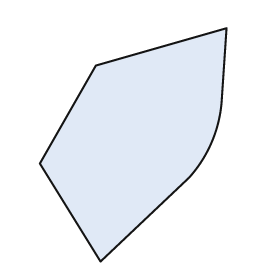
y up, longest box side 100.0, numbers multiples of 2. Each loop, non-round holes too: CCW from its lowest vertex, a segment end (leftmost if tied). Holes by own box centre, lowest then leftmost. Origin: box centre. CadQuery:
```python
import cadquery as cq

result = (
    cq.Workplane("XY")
    .moveTo(-14.0, -50.0)
    .lineTo(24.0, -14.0)
    .threePointArc((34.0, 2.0), (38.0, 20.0))
    .lineTo(40.0, 50.0)
    .lineTo(-16.0, 34.0)
    .lineTo(-40.0, -8.0)
    .close()
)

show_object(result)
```